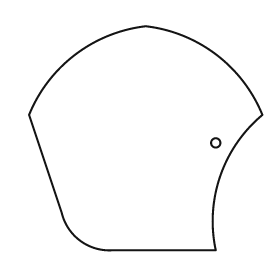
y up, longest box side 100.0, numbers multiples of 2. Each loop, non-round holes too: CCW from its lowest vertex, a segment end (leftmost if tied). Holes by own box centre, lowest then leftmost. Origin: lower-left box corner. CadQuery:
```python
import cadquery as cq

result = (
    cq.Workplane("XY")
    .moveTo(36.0, 0.0)
    .lineTo(80.0, 0.0)
    .threePointArc((82.0, 32.0), (100.0, 58.0))
    .threePointArc((80.0, 84.0), (50.0, 96.0))
    .threePointArc((20.0, 84.0), (0.0, 58.0))
    .lineTo(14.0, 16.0)
    .threePointArc((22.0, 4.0), (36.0, 0.0))
    .close()
    .moveTo(80.0, 46.0)
    .circle(2.0)
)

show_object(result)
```